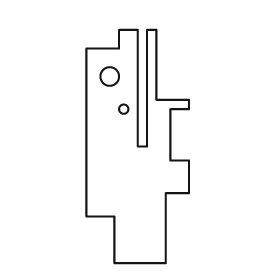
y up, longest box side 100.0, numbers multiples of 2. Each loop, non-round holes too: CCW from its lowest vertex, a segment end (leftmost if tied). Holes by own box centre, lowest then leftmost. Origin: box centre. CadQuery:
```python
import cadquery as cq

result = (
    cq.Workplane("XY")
    .moveTo(-10.0, -50.0)
    .lineTo(12.0, -50.0)
    .lineTo(12.0, -20.0)
    .lineTo(22.0, -20.0)
    .lineTo(22.0, -6.0)
    .lineTo(14.0, -6.0)
    .lineTo(14.0, 16.0)
    .lineTo(22.0, 16.0)
    .lineTo(22.0, 20.0)
    .lineTo(8.0, 20.0)
    .lineTo(8.0, 50.0)
    .lineTo(4.0, 50.0)
    .lineTo(4.0, 0.0)
    .lineTo(0.0, 0.0)
    .lineTo(0.0, 50.0)
    .lineTo(-8.0, 50.0)
    .lineTo(-8.0, 42.0)
    .lineTo(-22.0, 42.0)
    .lineTo(-22.0, -30.0)
    .lineTo(-10.0, -30.0)
    .close()
    .moveTo(-6.0, 16.0)
    .circle(2.0)
    .moveTo(-12.0, 30.0)
    .circle(4.0)
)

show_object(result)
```